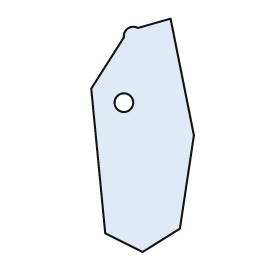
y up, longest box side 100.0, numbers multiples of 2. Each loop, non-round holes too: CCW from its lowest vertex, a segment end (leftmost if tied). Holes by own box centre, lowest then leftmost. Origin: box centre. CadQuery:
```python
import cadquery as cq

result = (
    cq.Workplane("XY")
    .moveTo(0.0, -50.0)
    .lineTo(16.0, -40.0)
    .lineTo(22.0, 0.0)
    .lineTo(12.0, 50.0)
    .lineTo(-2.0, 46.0)
    .threePointArc((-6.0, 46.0), (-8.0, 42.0))
    .lineTo(-22.0, 20.0)
    .lineTo(-16.0, -42.0)
    .close()
    .moveTo(-8.0, 14.0)
    .circle(4.0)
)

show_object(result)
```